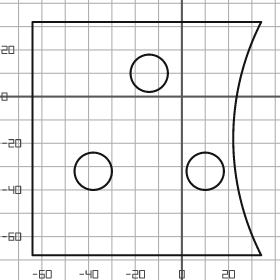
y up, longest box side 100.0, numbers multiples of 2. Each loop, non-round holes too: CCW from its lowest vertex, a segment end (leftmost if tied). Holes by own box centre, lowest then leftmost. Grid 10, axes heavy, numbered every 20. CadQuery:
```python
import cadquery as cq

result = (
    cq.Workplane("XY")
    .moveTo(-64.0, -68.0)
    .lineTo(34.0, -68.0)
    .threePointArc((22.0, -18.0), (34.0, 32.0))
    .lineTo(-64.0, 32.0)
    .close()
    .moveTo(-38.0, -32.0)
    .circle(8.0)
    .moveTo(10.0, -32.0)
    .circle(8.0)
    .moveTo(-14.0, 10.0)
    .circle(8.0)
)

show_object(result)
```